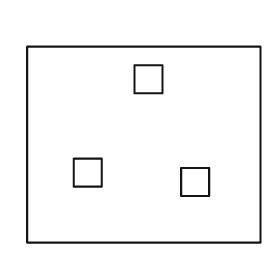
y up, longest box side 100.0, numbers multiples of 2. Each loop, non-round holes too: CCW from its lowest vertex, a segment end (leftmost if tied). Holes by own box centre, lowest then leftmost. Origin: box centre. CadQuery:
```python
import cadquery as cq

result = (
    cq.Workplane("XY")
    .moveTo(-50.0, -42.0)
    .lineTo(50.0, -42.0)
    .lineTo(50.0, 42.0)
    .lineTo(-50.0, 42.0)
    .close()
    .moveTo(16.0, -22.0)
    .lineTo(28.0, -22.0)
    .lineTo(28.0, -10.0)
    .lineTo(16.0, -10.0)
    .close()
    .moveTo(-30.0, -18.0)
    .lineTo(-18.0, -18.0)
    .lineTo(-18.0, -6.0)
    .lineTo(-30.0, -6.0)
    .close()
    .moveTo(-4.0, 22.0)
    .lineTo(8.0, 22.0)
    .lineTo(8.0, 34.0)
    .lineTo(-4.0, 34.0)
    .close()
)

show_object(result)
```